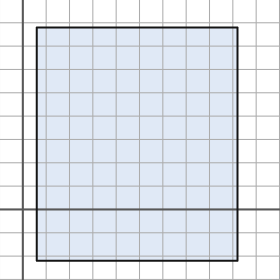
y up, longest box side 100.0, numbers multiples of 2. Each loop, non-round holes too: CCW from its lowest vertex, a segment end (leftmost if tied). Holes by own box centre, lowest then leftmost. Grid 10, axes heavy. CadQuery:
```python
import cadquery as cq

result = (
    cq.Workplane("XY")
    .moveTo(6.0, -22.0)
    .lineTo(92.0, -22.0)
    .lineTo(92.0, 78.0)
    .lineTo(6.0, 78.0)
    .close()
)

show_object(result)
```